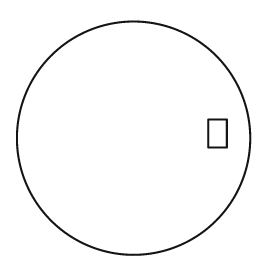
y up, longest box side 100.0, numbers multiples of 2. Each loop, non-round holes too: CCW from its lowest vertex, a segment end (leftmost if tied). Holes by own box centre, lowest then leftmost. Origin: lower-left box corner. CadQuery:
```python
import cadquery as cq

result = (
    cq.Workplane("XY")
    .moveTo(50.0, 50.0)
    .circle(50.0)
    .moveTo(82.0, 46.0)
    .lineTo(90.0, 46.0)
    .lineTo(90.0, 58.0)
    .lineTo(82.0, 58.0)
    .close()
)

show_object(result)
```